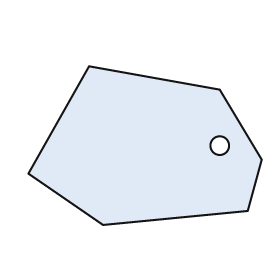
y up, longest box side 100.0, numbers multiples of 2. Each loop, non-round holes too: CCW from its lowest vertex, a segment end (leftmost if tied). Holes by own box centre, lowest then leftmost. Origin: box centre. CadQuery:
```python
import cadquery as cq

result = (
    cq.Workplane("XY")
    .moveTo(-18.0, -34.0)
    .lineTo(44.0, -28.0)
    .lineTo(50.0, -6.0)
    .lineTo(32.0, 24.0)
    .lineTo(-24.0, 34.0)
    .lineTo(-50.0, -12.0)
    .close()
    .moveTo(32.0, 0.0)
    .circle(4.0)
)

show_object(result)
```